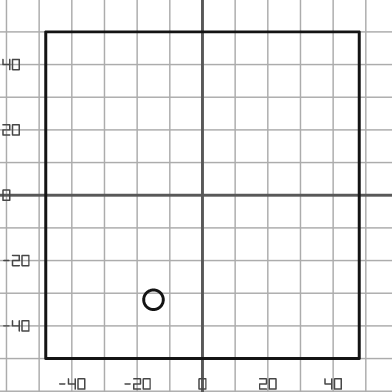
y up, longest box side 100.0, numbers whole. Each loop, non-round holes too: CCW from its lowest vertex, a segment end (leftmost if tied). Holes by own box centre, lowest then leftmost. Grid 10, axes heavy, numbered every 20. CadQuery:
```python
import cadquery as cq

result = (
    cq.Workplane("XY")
    .moveTo(-48.0, -50.0)
    .lineTo(48.0, -50.0)
    .lineTo(48.0, 50.0)
    .lineTo(-48.0, 50.0)
    .close()
    .moveTo(-15.0, -32.0)
    .circle(3.0)
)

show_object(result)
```